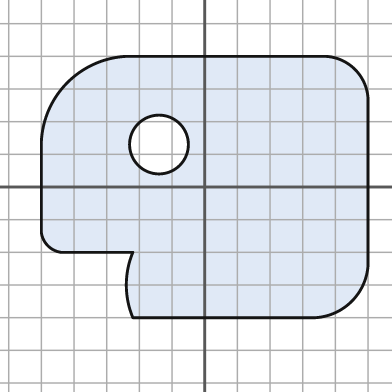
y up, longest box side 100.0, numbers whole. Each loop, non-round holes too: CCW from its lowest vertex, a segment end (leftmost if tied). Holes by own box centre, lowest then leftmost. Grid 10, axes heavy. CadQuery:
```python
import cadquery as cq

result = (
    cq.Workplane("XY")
    .moveTo(-22.0, -40.0)
    .lineTo(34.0, -40.0)
    .threePointArc((45.0, -35.0), (50.0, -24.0))
    .lineTo(50.0, 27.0)
    .threePointArc((46.0, 36.0), (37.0, 40.0))
    .lineTo(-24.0, 40.0)
    .threePointArc((-42.0, 32.0), (-50.0, 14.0))
    .lineTo(-50.0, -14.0)
    .threePointArc((-48.0, -18.0), (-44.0, -20.0))
    .lineTo(-22.0, -20.0)
    .threePointArc((-24.0, -30.0), (-22.0, -40.0))
    .close()
    .moveTo(-14.0, 13.0)
    .circle(9.0)
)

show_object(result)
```